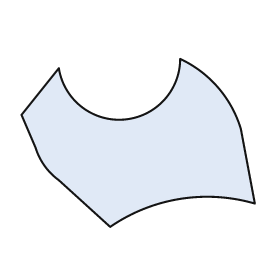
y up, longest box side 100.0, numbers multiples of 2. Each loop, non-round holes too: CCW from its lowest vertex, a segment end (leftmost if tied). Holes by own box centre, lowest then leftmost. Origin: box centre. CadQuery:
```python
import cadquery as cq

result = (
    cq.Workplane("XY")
    .moveTo(-12.0, -36.0)
    .threePointArc((18.0, -24.0), (50.0, -26.0))
    .lineTo(44.0, 6.0)
    .threePointArc((34.0, 24.0), (18.0, 36.0))
    .threePointArc((-6.0, 10.0), (-34.0, 32.0))
    .lineTo(-50.0, 12.0)
    .lineTo(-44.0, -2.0)
    .threePointArc((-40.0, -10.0), (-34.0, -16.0))
    .close()
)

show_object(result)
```